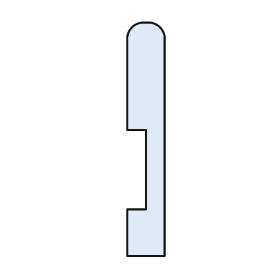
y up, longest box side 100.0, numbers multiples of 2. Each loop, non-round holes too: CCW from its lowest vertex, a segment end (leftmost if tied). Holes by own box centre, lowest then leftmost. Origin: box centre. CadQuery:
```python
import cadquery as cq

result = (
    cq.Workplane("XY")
    .moveTo(-8.0, -50.0)
    .lineTo(8.0, -50.0)
    .lineTo(8.0, 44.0)
    .threePointArc((6.0, 48.0), (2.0, 50.0))
    .lineTo(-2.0, 50.0)
    .threePointArc((-6.0, 48.0), (-8.0, 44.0))
    .lineTo(-8.0, 4.0)
    .lineTo(0.0, 4.0)
    .lineTo(0.0, -30.0)
    .lineTo(-8.0, -30.0)
    .close()
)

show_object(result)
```